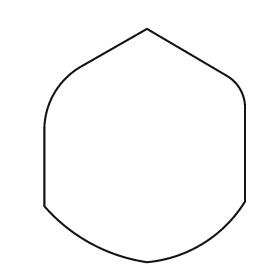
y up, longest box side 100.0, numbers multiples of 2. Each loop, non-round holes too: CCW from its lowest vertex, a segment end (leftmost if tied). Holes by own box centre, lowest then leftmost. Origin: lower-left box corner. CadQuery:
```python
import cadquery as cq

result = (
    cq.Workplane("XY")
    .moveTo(44.0, 0.0)
    .threePointArc((68.0, 8.0), (86.0, 26.0))
    .lineTo(86.0, 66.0)
    .threePointArc((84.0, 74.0), (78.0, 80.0))
    .lineTo(44.0, 100.0)
    .lineTo(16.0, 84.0)
    .threePointArc((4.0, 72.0), (0.0, 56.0))
    .lineTo(0.0, 24.0)
    .threePointArc((20.0, 8.0), (44.0, 0.0))
    .close()
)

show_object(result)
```